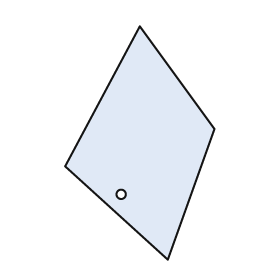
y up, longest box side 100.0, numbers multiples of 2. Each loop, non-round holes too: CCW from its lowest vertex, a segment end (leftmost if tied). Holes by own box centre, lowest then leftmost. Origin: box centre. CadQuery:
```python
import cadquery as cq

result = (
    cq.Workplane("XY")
    .moveTo(12.0, -50.0)
    .lineTo(32.0, 6.0)
    .lineTo(0.0, 50.0)
    .lineTo(-32.0, -10.0)
    .close()
    .moveTo(-8.0, -22.0)
    .circle(2.0)
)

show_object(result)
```